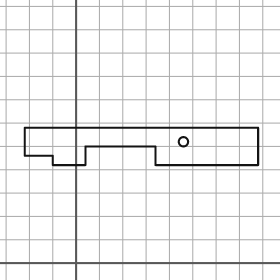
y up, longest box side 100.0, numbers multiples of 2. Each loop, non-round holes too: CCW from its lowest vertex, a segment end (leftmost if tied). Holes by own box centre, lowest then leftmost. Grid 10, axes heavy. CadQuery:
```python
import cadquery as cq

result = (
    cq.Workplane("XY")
    .moveTo(-10.0, 42.0)
    .lineTo(4.0, 42.0)
    .lineTo(4.0, 50.0)
    .lineTo(34.0, 50.0)
    .lineTo(34.0, 42.0)
    .lineTo(78.0, 42.0)
    .lineTo(78.0, 58.0)
    .lineTo(-22.0, 58.0)
    .lineTo(-22.0, 46.0)
    .lineTo(-10.0, 46.0)
    .close()
    .moveTo(46.0, 52.0)
    .circle(2.0)
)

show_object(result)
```